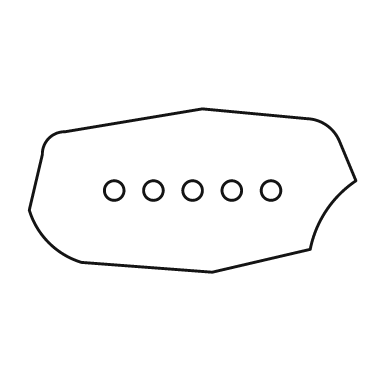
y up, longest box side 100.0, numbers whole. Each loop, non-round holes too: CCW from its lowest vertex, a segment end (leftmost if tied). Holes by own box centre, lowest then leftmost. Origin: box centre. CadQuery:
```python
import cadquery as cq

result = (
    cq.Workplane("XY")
    .moveTo(6.0, -25.0)
    .lineTo(36.0, -18.0)
    .threePointArc((41.0, -6.0), (50.0, 3.0))
    .lineTo(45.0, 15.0)
    .threePointArc((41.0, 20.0), (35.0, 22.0))
    .lineTo(3.0, 25.0)
    .lineTo(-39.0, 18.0)
    .threePointArc((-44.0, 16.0), (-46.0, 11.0))
    .lineTo(-50.0, -6.0)
    .threePointArc((-44.0, -16.0), (-34.0, -22.0))
    .close()
    .moveTo(-24.0, 0.0)
    .circle(3.0)
    .moveTo(-12.0, 0.0)
    .circle(3.0)
    .moveTo(0.0, 0.0)
    .circle(3.0)
    .moveTo(12.0, 0.0)
    .circle(3.0)
    .moveTo(24.0, 0.0)
    .circle(3.0)
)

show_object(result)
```